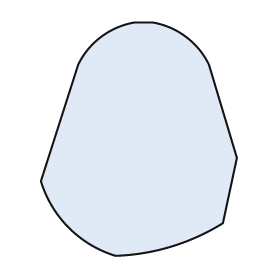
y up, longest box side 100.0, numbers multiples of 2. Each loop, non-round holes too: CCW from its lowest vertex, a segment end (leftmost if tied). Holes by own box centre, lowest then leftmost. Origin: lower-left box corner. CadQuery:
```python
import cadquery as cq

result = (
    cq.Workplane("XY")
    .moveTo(32.0, 0.0)
    .threePointArc((56.0, 4.0), (78.0, 14.0))
    .lineTo(84.0, 42.0)
    .lineTo(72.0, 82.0)
    .threePointArc((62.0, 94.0), (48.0, 100.0))
    .lineTo(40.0, 100.0)
    .threePointArc((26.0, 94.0), (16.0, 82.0))
    .lineTo(0.0, 32.0)
    .threePointArc((12.0, 12.0), (32.0, 0.0))
    .close()
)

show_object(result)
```